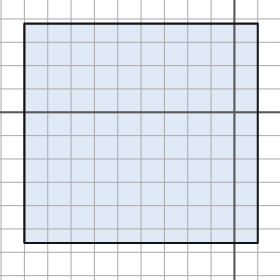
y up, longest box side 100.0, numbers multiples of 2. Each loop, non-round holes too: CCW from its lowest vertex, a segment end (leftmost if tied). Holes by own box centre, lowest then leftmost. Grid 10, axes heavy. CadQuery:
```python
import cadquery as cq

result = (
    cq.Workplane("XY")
    .moveTo(-90.0, -56.0)
    .lineTo(10.0, -56.0)
    .lineTo(10.0, 38.0)
    .lineTo(-90.0, 38.0)
    .close()
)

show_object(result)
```